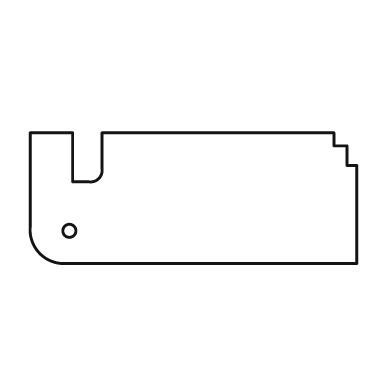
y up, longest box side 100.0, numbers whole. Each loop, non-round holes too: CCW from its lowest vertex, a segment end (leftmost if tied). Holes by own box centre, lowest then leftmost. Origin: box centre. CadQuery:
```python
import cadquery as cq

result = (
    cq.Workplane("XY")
    .moveTo(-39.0, -20.0)
    .lineTo(50.0, -20.0)
    .lineTo(50.0, 10.0)
    .lineTo(47.0, 10.0)
    .lineTo(47.0, 16.0)
    .lineTo(43.0, 16.0)
    .lineTo(43.0, 20.0)
    .lineTo(-28.0, 20.0)
    .lineTo(-28.0, 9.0)
    .threePointArc((-29.0, 6.0), (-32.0, 5.0))
    .lineTo(-37.0, 5.0)
    .lineTo(-37.0, 20.0)
    .lineTo(-50.0, 20.0)
    .lineTo(-50.0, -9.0)
    .threePointArc((-47.0, -17.0), (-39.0, -20.0))
    .close()
    .moveTo(-38.0, -10.0)
    .circle(2.0)
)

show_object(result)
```